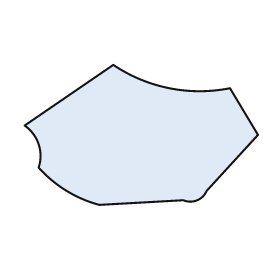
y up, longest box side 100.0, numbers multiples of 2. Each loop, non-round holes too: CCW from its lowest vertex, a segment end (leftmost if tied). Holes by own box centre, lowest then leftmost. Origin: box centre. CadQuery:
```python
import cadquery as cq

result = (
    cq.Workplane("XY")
    .moveTo(-18.0, -30.0)
    .lineTo(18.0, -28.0)
    .threePointArc((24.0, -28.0), (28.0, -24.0))
    .lineTo(50.0, 0.0)
    .lineTo(38.0, 20.0)
    .threePointArc((12.0, 20.0), (-12.0, 30.0))
    .lineTo(-50.0, 4.0)
    .threePointArc((-44.0, -4.0), (-44.0, -14.0))
    .threePointArc((-32.0, -24.0), (-18.0, -30.0))
    .close()
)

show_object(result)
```